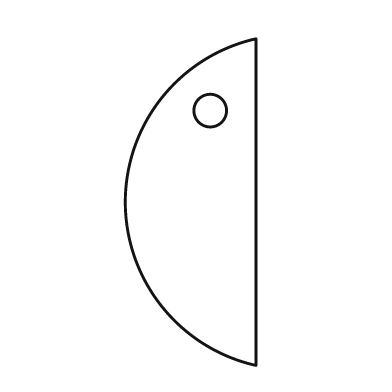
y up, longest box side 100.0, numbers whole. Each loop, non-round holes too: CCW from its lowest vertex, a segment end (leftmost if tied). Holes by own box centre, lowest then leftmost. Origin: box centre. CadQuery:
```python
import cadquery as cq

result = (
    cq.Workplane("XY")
    .moveTo(20.0, -50.0)
    .lineTo(20.0, 50.0)
    .threePointArc((-20.0, 0.0), (20.0, -50.0))
    .close()
    .moveTo(6.0, 28.0)
    .circle(5.0)
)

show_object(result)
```